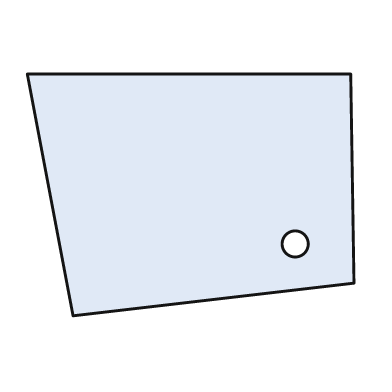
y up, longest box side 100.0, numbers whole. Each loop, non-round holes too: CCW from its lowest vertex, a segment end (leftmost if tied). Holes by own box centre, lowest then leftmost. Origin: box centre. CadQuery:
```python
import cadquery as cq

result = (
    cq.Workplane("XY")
    .moveTo(-36.0, -37.0)
    .lineTo(50.0, -27.0)
    .lineTo(49.0, 37.0)
    .lineTo(-50.0, 37.0)
    .close()
    .moveTo(32.0, -15.0)
    .circle(4.0)
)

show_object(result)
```